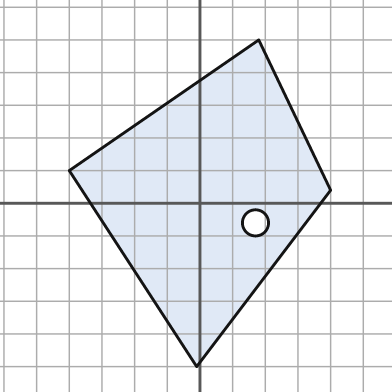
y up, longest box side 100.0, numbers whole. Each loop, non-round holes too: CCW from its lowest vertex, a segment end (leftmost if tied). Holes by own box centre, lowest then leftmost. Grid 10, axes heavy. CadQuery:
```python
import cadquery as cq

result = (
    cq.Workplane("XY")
    .moveTo(-1.0, -50.0)
    .lineTo(40.0, 4.0)
    .lineTo(18.0, 50.0)
    .lineTo(-40.0, 10.0)
    .close()
    .moveTo(17.0, -6.0)
    .circle(4.0)
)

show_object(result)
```